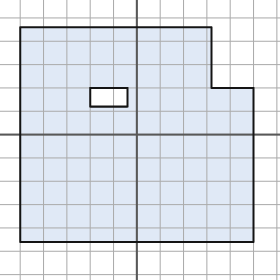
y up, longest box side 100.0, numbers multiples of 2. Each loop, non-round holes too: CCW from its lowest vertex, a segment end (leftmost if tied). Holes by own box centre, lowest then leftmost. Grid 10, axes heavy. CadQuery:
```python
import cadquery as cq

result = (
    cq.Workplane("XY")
    .moveTo(-50.0, -46.0)
    .lineTo(50.0, -46.0)
    .lineTo(50.0, 20.0)
    .lineTo(32.0, 20.0)
    .lineTo(32.0, 46.0)
    .lineTo(-50.0, 46.0)
    .close()
    .moveTo(-20.0, 12.0)
    .lineTo(-4.0, 12.0)
    .lineTo(-4.0, 20.0)
    .lineTo(-20.0, 20.0)
    .close()
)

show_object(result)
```